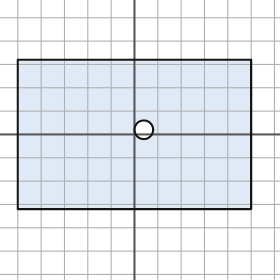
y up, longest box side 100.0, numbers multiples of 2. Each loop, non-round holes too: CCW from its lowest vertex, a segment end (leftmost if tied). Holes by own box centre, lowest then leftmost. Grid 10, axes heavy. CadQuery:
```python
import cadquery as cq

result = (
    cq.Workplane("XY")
    .moveTo(-50.0, -32.0)
    .lineTo(50.0, -32.0)
    .lineTo(50.0, 32.0)
    .lineTo(-50.0, 32.0)
    .close()
    .moveTo(4.0, 2.0)
    .circle(4.0)
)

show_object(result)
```